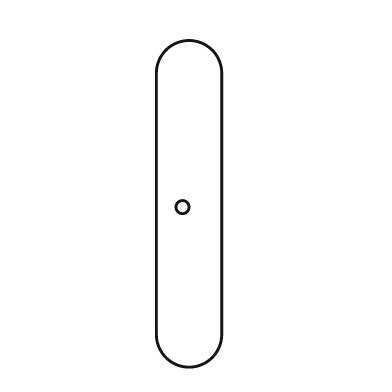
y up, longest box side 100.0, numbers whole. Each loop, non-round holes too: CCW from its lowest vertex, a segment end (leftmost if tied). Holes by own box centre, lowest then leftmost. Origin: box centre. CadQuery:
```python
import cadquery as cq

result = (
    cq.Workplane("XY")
    .moveTo(-10.0, -40.0)
    .threePointArc((0.0, -50.0), (10.0, -40.0))
    .lineTo(10.0, 40.0)
    .threePointArc((0.0, 50.0), (-10.0, 40.0))
    .close()
    .moveTo(-2.0, -1.0)
    .circle(2.0)
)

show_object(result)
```